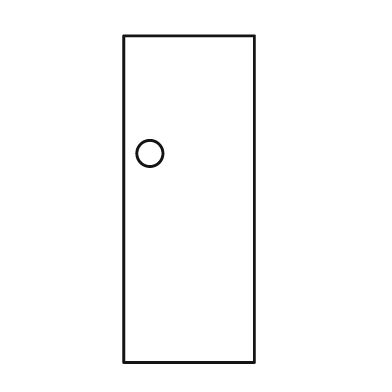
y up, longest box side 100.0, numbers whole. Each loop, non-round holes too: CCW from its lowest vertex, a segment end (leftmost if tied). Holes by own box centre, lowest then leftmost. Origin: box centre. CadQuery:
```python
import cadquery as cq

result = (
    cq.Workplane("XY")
    .moveTo(-20.0, -50.0)
    .lineTo(20.0, -50.0)
    .lineTo(20.0, 50.0)
    .lineTo(-20.0, 50.0)
    .close()
    .moveTo(-12.0, 14.0)
    .circle(4.0)
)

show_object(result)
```